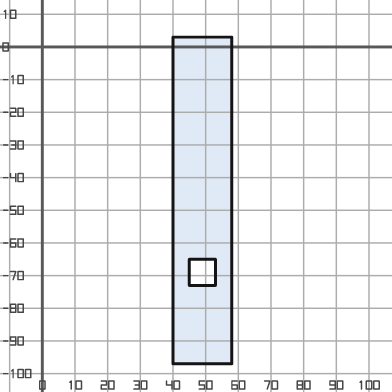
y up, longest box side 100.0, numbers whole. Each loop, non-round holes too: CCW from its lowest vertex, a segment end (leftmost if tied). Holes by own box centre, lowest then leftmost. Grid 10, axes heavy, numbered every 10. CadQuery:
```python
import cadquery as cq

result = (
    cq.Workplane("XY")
    .moveTo(40.0, -97.0)
    .lineTo(58.0, -97.0)
    .lineTo(58.0, 3.0)
    .lineTo(40.0, 3.0)
    .close()
    .moveTo(45.0, -73.0)
    .lineTo(53.0, -73.0)
    .lineTo(53.0, -65.0)
    .lineTo(45.0, -65.0)
    .close()
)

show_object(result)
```